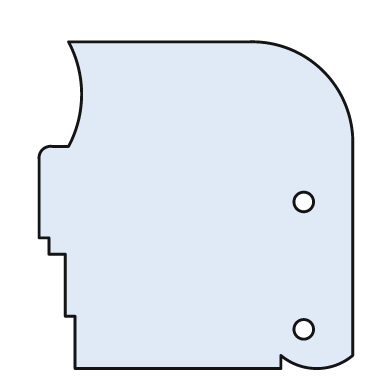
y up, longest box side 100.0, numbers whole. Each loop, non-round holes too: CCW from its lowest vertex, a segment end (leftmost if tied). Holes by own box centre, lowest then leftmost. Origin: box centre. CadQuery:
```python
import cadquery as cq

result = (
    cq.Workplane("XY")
    .moveTo(-37.0, -50.0)
    .lineTo(26.0, -50.0)
    .lineTo(26.0, -46.0)
    .threePointArc((37.0, -50.0), (48.0, -46.0))
    .lineTo(48.0, 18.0)
    .threePointArc((39.0, 41.0), (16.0, 50.0))
    .lineTo(-39.0, 50.0)
    .threePointArc((-35.0, 34.0), (-39.0, 18.0))
    .lineTo(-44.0, 18.0)
    .threePointArc((-47.0, 17.0), (-48.0, 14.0))
    .lineTo(-48.0, -10.0)
    .lineTo(-45.0, -10.0)
    .lineTo(-45.0, -15.0)
    .lineTo(-40.0, -15.0)
    .lineTo(-40.0, -34.0)
    .lineTo(-37.0, -34.0)
    .close()
    .moveTo(33.0, -38.0)
    .circle(3.0)
    .moveTo(33.0, 1.0)
    .circle(3.0)
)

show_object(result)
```